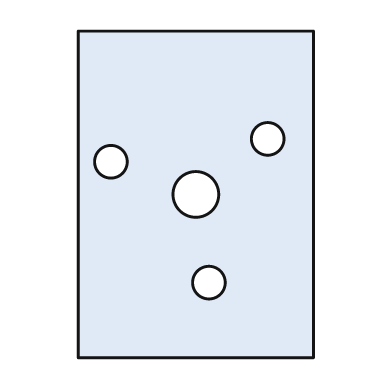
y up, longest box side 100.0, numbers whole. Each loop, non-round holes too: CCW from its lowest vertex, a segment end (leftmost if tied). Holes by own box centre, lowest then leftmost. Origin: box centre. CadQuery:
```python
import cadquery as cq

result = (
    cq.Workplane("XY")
    .moveTo(-36.0, -50.0)
    .lineTo(36.0, -50.0)
    .lineTo(36.0, 50.0)
    .lineTo(-36.0, 50.0)
    .close()
    .moveTo(4.0, -27.0)
    .circle(5.0)
    .moveTo(0.0, 0.0)
    .circle(7.0)
    .moveTo(-26.0, 10.0)
    .circle(5.0)
    .moveTo(22.0, 17.0)
    .circle(5.0)
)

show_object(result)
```